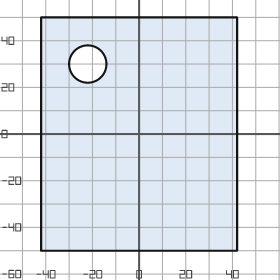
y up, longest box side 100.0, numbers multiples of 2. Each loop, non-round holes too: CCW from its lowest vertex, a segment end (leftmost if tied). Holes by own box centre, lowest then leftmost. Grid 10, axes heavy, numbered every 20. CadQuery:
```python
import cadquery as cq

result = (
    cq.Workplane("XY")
    .moveTo(-42.0, -50.0)
    .lineTo(42.0, -50.0)
    .lineTo(42.0, 50.0)
    .lineTo(-42.0, 50.0)
    .close()
    .moveTo(-22.0, 30.0)
    .circle(8.0)
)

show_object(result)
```